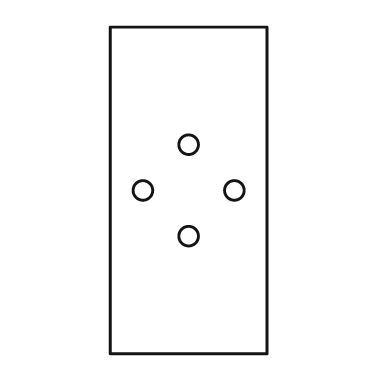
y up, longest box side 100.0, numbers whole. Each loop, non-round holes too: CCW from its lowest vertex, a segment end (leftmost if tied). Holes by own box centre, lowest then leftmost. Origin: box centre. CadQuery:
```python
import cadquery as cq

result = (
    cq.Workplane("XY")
    .moveTo(-24.0, -50.0)
    .lineTo(24.0, -50.0)
    .lineTo(24.0, 50.0)
    .lineTo(-24.0, 50.0)
    .close()
    .moveTo(0.0, -14.0)
    .circle(3.0)
    .moveTo(-14.0, 0.0)
    .circle(3.0)
    .moveTo(14.0, 0.0)
    .circle(3.0)
    .moveTo(0.0, 14.0)
    .circle(3.0)
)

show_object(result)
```